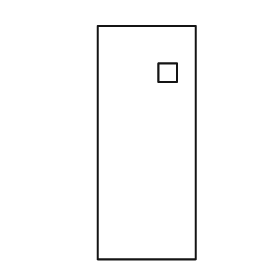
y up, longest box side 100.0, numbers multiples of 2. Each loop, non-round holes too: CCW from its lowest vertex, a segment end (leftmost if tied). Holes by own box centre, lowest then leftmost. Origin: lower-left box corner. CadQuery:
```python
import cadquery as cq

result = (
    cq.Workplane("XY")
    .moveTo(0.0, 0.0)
    .lineTo(42.0, 0.0)
    .lineTo(42.0, 100.0)
    .lineTo(0.0, 100.0)
    .close()
    .moveTo(26.0, 76.0)
    .lineTo(34.0, 76.0)
    .lineTo(34.0, 84.0)
    .lineTo(26.0, 84.0)
    .close()
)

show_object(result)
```